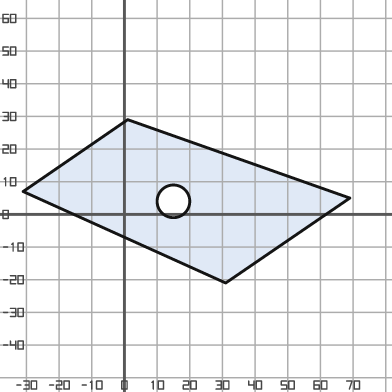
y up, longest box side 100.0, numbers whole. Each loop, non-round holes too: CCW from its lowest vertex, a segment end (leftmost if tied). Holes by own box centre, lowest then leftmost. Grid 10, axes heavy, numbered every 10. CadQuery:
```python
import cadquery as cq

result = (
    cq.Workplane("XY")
    .moveTo(31.0, -21.0)
    .lineTo(69.0, 5.0)
    .lineTo(1.0, 29.0)
    .lineTo(-31.0, 7.0)
    .close()
    .moveTo(15.0, 4.0)
    .circle(5.0)
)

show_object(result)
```